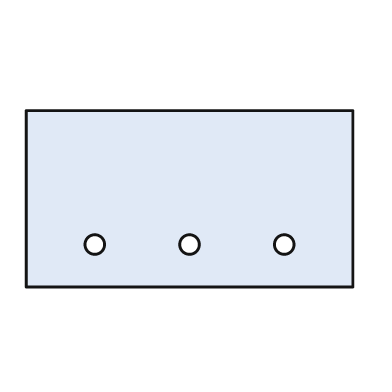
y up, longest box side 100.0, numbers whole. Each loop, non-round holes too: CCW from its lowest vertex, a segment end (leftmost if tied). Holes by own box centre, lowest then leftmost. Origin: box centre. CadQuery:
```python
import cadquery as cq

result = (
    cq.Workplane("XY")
    .moveTo(-50.0, -27.0)
    .lineTo(50.0, -27.0)
    .lineTo(50.0, 27.0)
    .lineTo(-50.0, 27.0)
    .close()
    .moveTo(-29.0, -14.0)
    .circle(3.0)
    .moveTo(0.0, -14.0)
    .circle(3.0)
    .moveTo(29.0, -14.0)
    .circle(3.0)
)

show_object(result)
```